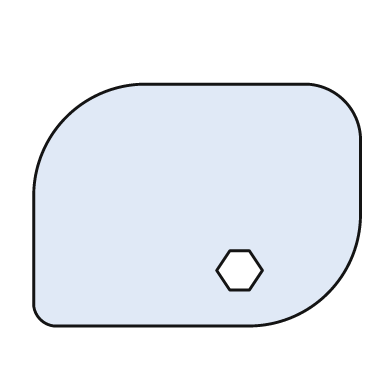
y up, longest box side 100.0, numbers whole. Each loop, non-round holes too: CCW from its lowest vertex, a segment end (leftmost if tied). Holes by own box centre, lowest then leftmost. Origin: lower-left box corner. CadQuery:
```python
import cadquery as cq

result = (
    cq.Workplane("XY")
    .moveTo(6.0, 0.0)
    .lineTo(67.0, 0.0)
    .threePointArc((90.0, 10.0), (100.0, 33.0))
    .lineTo(100.0, 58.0)
    .threePointArc((95.0, 69.0), (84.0, 74.0))
    .lineTo(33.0, 74.0)
    .threePointArc((10.0, 64.0), (0.0, 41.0))
    .lineTo(0.0, 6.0)
    .threePointArc((2.0, 2.0), (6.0, 0.0))
    .close()
    .moveTo(60.0, 11.0)
    .lineTo(66.0, 11.0)
    .lineTo(70.0, 17.0)
    .lineTo(66.0, 23.0)
    .lineTo(60.0, 23.0)
    .lineTo(56.0, 17.0)
    .close()
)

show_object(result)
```